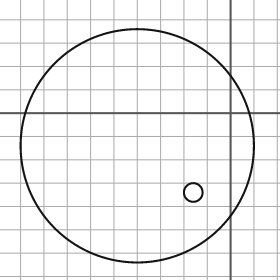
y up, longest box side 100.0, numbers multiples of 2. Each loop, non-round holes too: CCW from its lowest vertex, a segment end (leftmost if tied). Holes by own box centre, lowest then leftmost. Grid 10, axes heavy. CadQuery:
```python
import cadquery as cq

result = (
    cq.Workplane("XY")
    .moveTo(-40.0, -14.0)
    .circle(50.0)
    .moveTo(-16.0, -34.0)
    .circle(4.0)
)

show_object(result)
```